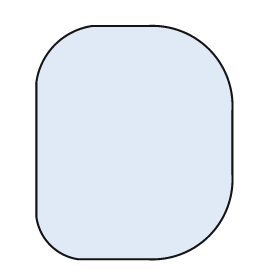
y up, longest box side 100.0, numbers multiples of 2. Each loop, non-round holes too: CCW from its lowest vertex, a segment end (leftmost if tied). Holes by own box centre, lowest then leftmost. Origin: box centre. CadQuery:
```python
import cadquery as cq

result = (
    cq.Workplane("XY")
    .moveTo(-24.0, -50.0)
    .lineTo(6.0, -50.0)
    .threePointArc((32.0, -40.0), (42.0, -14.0))
    .lineTo(42.0, 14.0)
    .threePointArc((32.0, 40.0), (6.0, 50.0))
    .lineTo(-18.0, 50.0)
    .threePointArc((-34.0, 42.0), (-42.0, 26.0))
    .lineTo(-42.0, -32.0)
    .threePointArc((-36.0, -44.0), (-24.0, -50.0))
    .close()
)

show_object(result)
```